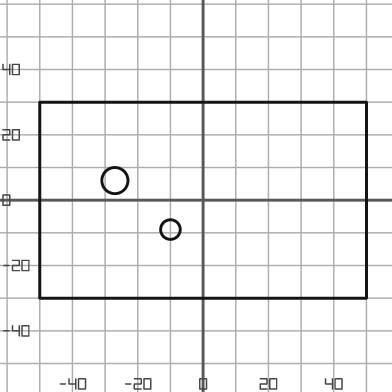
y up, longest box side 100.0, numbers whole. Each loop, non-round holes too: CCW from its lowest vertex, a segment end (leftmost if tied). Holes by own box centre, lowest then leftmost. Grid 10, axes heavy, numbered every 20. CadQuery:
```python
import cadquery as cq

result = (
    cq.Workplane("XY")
    .moveTo(-50.0, -30.0)
    .lineTo(50.0, -30.0)
    .lineTo(50.0, 30.0)
    .lineTo(-50.0, 30.0)
    .close()
    .moveTo(-10.0, -9.0)
    .circle(3.0)
    .moveTo(-27.0, 6.0)
    .circle(4.0)
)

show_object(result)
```